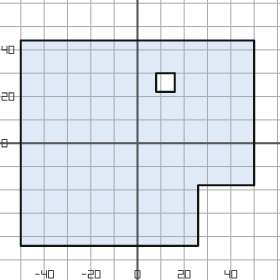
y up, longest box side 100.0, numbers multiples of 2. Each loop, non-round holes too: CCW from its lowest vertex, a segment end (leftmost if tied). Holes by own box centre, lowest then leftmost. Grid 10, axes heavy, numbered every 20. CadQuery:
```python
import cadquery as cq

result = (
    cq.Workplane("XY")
    .moveTo(-50.0, -44.0)
    .lineTo(26.0, -44.0)
    .lineTo(26.0, -18.0)
    .lineTo(50.0, -18.0)
    .lineTo(50.0, 44.0)
    .lineTo(-50.0, 44.0)
    .close()
    .moveTo(8.0, 22.0)
    .lineTo(16.0, 22.0)
    .lineTo(16.0, 30.0)
    .lineTo(8.0, 30.0)
    .close()
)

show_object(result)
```